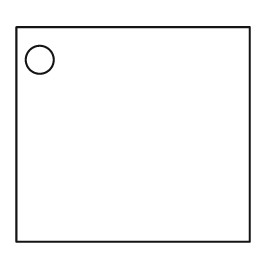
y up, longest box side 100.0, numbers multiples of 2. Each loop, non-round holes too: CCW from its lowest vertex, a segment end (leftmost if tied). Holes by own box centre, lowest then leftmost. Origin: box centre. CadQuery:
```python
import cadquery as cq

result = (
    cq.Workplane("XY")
    .moveTo(-50.0, -46.0)
    .lineTo(50.0, -46.0)
    .lineTo(50.0, 46.0)
    .lineTo(-50.0, 46.0)
    .close()
    .moveTo(-40.0, 32.0)
    .circle(6.0)
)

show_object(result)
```